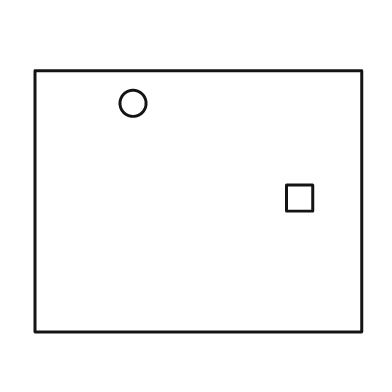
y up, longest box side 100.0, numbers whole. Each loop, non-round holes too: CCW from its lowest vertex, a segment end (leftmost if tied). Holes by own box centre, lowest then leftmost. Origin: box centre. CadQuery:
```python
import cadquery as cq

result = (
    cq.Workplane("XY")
    .moveTo(-50.0, -40.0)
    .lineTo(50.0, -40.0)
    .lineTo(50.0, 40.0)
    .lineTo(-50.0, 40.0)
    .close()
    .moveTo(27.0, -3.0)
    .lineTo(35.0, -3.0)
    .lineTo(35.0, 5.0)
    .lineTo(27.0, 5.0)
    .close()
    .moveTo(-20.0, 30.0)
    .circle(4.0)
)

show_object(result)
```